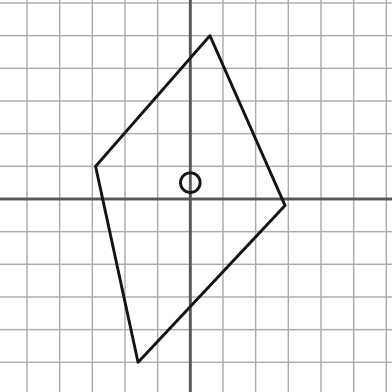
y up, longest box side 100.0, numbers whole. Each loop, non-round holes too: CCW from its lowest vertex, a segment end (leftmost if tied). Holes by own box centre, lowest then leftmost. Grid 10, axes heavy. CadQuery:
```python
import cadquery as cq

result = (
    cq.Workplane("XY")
    .moveTo(-16.0, -50.0)
    .lineTo(29.0, -2.0)
    .lineTo(6.0, 50.0)
    .lineTo(-29.0, 10.0)
    .close()
    .moveTo(0.0, 5.0)
    .circle(3.0)
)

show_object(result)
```